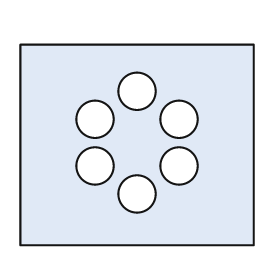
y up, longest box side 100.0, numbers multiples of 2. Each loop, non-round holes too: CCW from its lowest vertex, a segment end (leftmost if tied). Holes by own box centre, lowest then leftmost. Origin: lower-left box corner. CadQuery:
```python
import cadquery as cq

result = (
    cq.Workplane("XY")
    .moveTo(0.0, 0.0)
    .lineTo(100.0, 0.0)
    .lineTo(100.0, 86.0)
    .lineTo(0.0, 86.0)
    .close()
    .moveTo(50.0, 22.0)
    .circle(8.0)
    .moveTo(32.0, 34.0)
    .circle(8.0)
    .moveTo(68.0, 34.0)
    .circle(8.0)
    .moveTo(32.0, 54.0)
    .circle(8.0)
    .moveTo(68.0, 54.0)
    .circle(8.0)
    .moveTo(50.0, 66.0)
    .circle(8.0)
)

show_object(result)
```